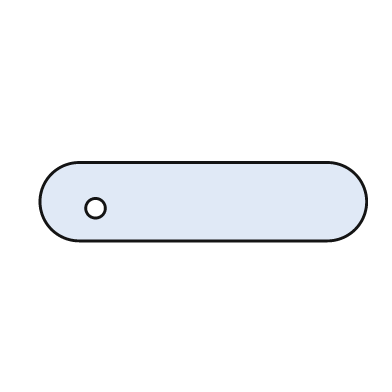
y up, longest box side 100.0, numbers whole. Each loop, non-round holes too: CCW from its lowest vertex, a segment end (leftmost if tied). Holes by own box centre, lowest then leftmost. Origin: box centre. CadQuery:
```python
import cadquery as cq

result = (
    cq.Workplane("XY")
    .moveTo(-38.0, -12.0)
    .lineTo(38.0, -12.0)
    .threePointArc((50.0, 0.0), (38.0, 12.0))
    .lineTo(-38.0, 12.0)
    .threePointArc((-50.0, 0.0), (-38.0, -12.0))
    .close()
    .moveTo(-33.0, -2.0)
    .circle(3.0)
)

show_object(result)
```